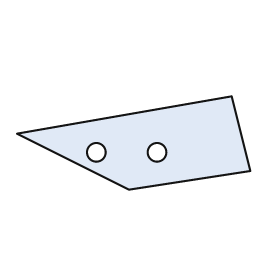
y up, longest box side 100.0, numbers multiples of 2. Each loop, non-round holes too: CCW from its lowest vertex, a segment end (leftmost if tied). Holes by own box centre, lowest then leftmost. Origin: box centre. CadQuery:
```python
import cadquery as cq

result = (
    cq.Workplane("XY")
    .moveTo(-2.0, -20.0)
    .lineTo(50.0, -12.0)
    .lineTo(42.0, 20.0)
    .lineTo(-50.0, 4.0)
    .close()
    .moveTo(-16.0, -4.0)
    .circle(4.0)
    .moveTo(10.0, -4.0)
    .circle(4.0)
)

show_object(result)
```